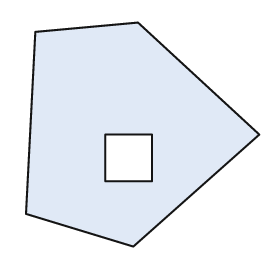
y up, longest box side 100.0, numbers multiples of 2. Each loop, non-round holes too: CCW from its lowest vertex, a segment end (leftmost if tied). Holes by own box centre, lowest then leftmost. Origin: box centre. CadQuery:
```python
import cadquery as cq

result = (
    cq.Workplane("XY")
    .moveTo(-4.0, -48.0)
    .lineTo(50.0, 0.0)
    .lineTo(-2.0, 48.0)
    .lineTo(-46.0, 44.0)
    .lineTo(-50.0, -34.0)
    .close()
    .moveTo(-16.0, -20.0)
    .lineTo(4.0, -20.0)
    .lineTo(4.0, 0.0)
    .lineTo(-16.0, 0.0)
    .close()
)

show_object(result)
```